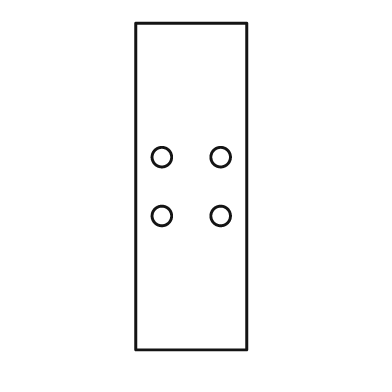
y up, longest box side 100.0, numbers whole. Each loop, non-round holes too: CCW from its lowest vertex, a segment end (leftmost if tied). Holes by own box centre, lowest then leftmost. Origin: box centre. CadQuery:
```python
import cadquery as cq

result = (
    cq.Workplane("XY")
    .moveTo(-17.0, -50.0)
    .lineTo(17.0, -50.0)
    .lineTo(17.0, 50.0)
    .lineTo(-17.0, 50.0)
    .close()
    .moveTo(-9.0, -9.0)
    .circle(3.0)
    .moveTo(9.0, -9.0)
    .circle(3.0)
    .moveTo(-9.0, 9.0)
    .circle(3.0)
    .moveTo(9.0, 9.0)
    .circle(3.0)
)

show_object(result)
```